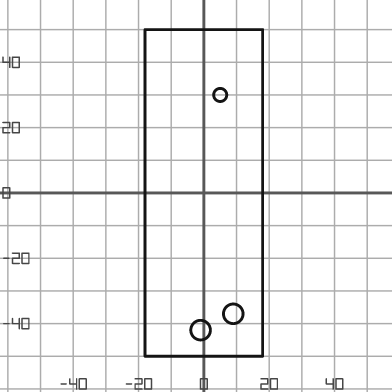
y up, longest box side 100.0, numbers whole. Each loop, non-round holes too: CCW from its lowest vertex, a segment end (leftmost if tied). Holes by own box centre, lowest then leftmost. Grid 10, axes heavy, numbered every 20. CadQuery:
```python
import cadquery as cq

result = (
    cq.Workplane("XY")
    .moveTo(-18.0, -50.0)
    .lineTo(18.0, -50.0)
    .lineTo(18.0, 50.0)
    .lineTo(-18.0, 50.0)
    .close()
    .moveTo(-1.0, -42.0)
    .circle(3.0)
    .moveTo(9.0, -37.0)
    .circle(3.0)
    .moveTo(5.0, 30.0)
    .circle(2.0)
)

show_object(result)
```